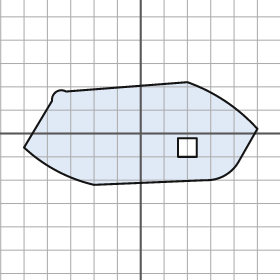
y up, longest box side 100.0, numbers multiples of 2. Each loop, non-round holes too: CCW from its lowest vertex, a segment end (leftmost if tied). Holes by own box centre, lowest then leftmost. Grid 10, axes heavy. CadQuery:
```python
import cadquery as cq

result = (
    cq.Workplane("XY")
    .moveTo(-20.0, -22.0)
    .lineTo(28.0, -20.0)
    .threePointArc((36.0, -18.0), (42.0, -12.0))
    .lineTo(50.0, 2.0)
    .threePointArc((36.0, 14.0), (20.0, 22.0))
    .lineTo(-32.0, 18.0)
    .threePointArc((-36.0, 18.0), (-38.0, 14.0))
    .lineTo(-50.0, -6.0)
    .threePointArc((-36.0, -16.0), (-20.0, -22.0))
    .close()
    .moveTo(16.0, -10.0)
    .lineTo(24.0, -10.0)
    .lineTo(24.0, -2.0)
    .lineTo(16.0, -2.0)
    .close()
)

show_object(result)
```